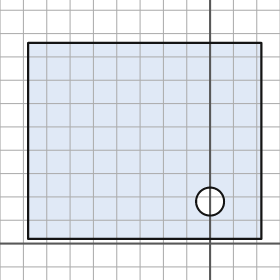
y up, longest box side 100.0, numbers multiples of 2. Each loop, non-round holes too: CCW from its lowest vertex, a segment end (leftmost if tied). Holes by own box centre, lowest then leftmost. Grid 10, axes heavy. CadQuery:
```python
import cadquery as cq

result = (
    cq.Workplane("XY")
    .moveTo(-78.0, 2.0)
    .lineTo(22.0, 2.0)
    .lineTo(22.0, 86.0)
    .lineTo(-78.0, 86.0)
    .close()
    .moveTo(0.0, 18.0)
    .circle(6.0)
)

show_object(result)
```